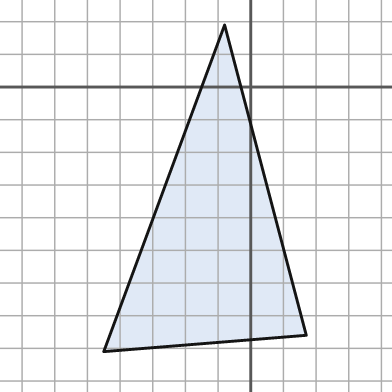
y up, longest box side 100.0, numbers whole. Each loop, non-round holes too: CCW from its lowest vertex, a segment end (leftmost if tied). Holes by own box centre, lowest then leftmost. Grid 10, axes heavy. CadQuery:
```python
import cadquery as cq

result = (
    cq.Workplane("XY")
    .moveTo(-45.0, -81.0)
    .lineTo(17.0, -76.0)
    .lineTo(-8.0, 19.0)
    .close()
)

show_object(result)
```